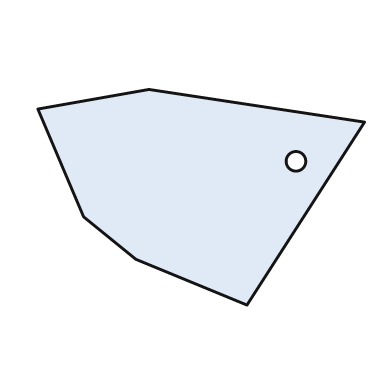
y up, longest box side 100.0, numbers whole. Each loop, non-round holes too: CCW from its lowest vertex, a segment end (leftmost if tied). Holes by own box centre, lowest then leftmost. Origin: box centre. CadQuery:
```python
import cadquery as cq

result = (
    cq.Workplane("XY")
    .moveTo(14.0, -33.0)
    .lineTo(50.0, 23.0)
    .lineTo(-16.0, 33.0)
    .lineTo(-50.0, 27.0)
    .lineTo(-36.0, -6.0)
    .lineTo(-20.0, -19.0)
    .close()
    .moveTo(29.0, 11.0)
    .circle(3.0)
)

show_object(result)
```